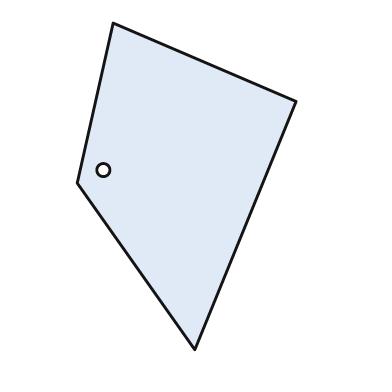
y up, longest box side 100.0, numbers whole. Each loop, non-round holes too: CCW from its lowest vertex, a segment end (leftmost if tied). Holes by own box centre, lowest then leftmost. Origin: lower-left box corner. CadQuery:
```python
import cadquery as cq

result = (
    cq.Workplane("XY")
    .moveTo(36.0, 0.0)
    .lineTo(67.0, 76.0)
    .lineTo(11.0, 100.0)
    .lineTo(0.0, 51.0)
    .close()
    .moveTo(8.0, 55.0)
    .circle(2.0)
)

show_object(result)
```